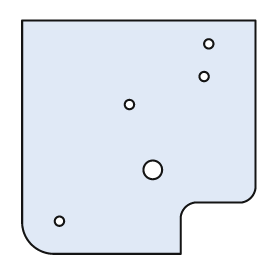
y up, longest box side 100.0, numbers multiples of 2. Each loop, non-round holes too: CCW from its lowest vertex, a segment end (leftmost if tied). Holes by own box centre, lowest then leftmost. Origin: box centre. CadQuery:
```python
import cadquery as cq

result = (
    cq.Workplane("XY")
    .moveTo(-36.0, -50.0)
    .lineTo(18.0, -50.0)
    .lineTo(18.0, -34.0)
    .threePointArc((20.0, -30.0), (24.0, -28.0))
    .lineTo(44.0, -28.0)
    .threePointArc((48.0, -26.0), (50.0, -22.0))
    .lineTo(50.0, 50.0)
    .lineTo(-50.0, 50.0)
    .lineTo(-50.0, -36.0)
    .threePointArc((-46.0, -46.0), (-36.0, -50.0))
    .close()
    .moveTo(-34.0, -36.0)
    .circle(2.0)
    .moveTo(6.0, -14.0)
    .circle(4.0)
    .moveTo(-4.0, 14.0)
    .circle(2.0)
    .moveTo(28.0, 26.0)
    .circle(2.0)
    .moveTo(30.0, 40.0)
    .circle(2.0)
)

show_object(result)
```